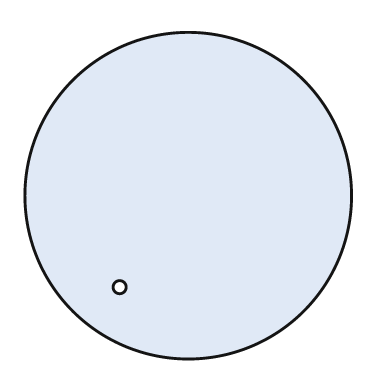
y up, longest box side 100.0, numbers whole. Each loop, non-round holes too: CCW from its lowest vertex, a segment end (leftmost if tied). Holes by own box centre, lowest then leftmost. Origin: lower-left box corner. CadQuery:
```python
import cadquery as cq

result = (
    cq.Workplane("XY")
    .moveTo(50.0, 50.0)
    .circle(50.0)
    .moveTo(29.0, 22.0)
    .circle(2.0)
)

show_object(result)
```